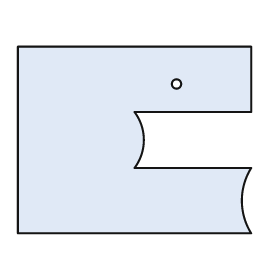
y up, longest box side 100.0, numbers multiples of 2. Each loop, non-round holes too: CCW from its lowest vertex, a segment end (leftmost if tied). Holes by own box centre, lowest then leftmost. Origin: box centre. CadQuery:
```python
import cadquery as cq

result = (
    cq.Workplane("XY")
    .moveTo(-50.0, -40.0)
    .lineTo(50.0, -40.0)
    .threePointArc((46.0, -26.0), (50.0, -12.0))
    .lineTo(0.0, -12.0)
    .threePointArc((4.0, 0.0), (0.0, 12.0))
    .lineTo(50.0, 12.0)
    .lineTo(50.0, 40.0)
    .lineTo(-50.0, 40.0)
    .close()
    .moveTo(18.0, 24.0)
    .circle(2.0)
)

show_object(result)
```